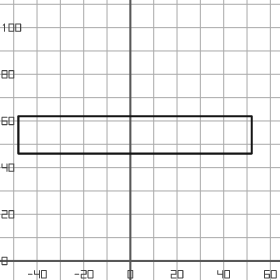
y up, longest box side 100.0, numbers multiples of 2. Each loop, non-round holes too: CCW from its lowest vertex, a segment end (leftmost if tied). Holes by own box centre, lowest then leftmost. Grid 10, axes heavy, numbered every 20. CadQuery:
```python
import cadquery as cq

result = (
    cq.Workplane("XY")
    .moveTo(-48.0, 46.0)
    .lineTo(52.0, 46.0)
    .lineTo(52.0, 62.0)
    .lineTo(-48.0, 62.0)
    .close()
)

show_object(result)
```